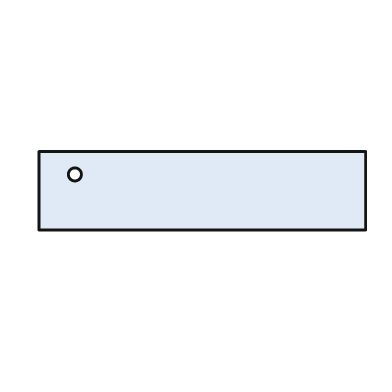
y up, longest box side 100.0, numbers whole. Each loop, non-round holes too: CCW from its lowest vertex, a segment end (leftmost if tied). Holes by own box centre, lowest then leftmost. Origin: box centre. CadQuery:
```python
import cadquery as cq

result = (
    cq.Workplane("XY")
    .moveTo(-50.0, -12.0)
    .lineTo(50.0, -12.0)
    .lineTo(50.0, 12.0)
    .lineTo(-50.0, 12.0)
    .close()
    .moveTo(-39.0, 5.0)
    .circle(2.0)
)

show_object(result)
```